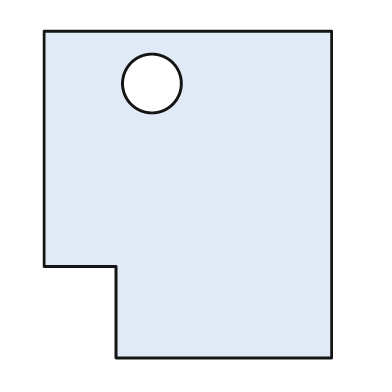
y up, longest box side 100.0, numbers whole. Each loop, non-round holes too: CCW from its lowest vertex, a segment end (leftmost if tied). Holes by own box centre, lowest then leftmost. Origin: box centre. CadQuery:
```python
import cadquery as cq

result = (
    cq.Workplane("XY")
    .moveTo(-22.0, -50.0)
    .lineTo(44.0, -50.0)
    .lineTo(44.0, 50.0)
    .lineTo(-44.0, 50.0)
    .lineTo(-44.0, -22.0)
    .lineTo(-22.0, -22.0)
    .close()
    .moveTo(-11.0, 34.0)
    .circle(9.0)
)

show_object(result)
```